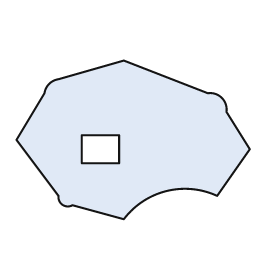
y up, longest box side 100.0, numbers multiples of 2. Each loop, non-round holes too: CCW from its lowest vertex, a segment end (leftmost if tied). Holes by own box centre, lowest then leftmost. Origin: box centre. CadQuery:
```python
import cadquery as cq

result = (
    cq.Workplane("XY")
    .moveTo(-4.0, -34.0)
    .threePointArc((14.0, -22.0), (36.0, -24.0))
    .lineTo(50.0, -4.0)
    .lineTo(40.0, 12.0)
    .threePointArc((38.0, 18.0), (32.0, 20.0))
    .lineTo(-4.0, 34.0)
    .lineTo(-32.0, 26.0)
    .threePointArc((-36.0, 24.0), (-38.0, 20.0))
    .lineTo(-50.0, 0.0)
    .lineTo(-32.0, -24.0)
    .threePointArc((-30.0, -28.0), (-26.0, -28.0))
    .close()
    .moveTo(-22.0, -10.0)
    .lineTo(-6.0, -10.0)
    .lineTo(-6.0, 2.0)
    .lineTo(-22.0, 2.0)
    .close()
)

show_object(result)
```